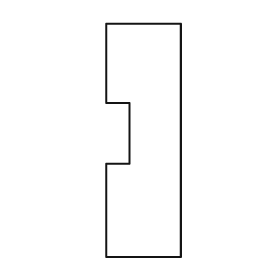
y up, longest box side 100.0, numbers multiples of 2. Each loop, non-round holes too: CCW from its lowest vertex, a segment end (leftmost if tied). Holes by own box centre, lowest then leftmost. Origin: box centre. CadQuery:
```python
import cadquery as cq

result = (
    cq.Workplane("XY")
    .moveTo(-16.0, -50.0)
    .lineTo(16.0, -50.0)
    .lineTo(16.0, 50.0)
    .lineTo(-16.0, 50.0)
    .lineTo(-16.0, 16.0)
    .lineTo(-6.0, 16.0)
    .lineTo(-6.0, -10.0)
    .lineTo(-16.0, -10.0)
    .close()
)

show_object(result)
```